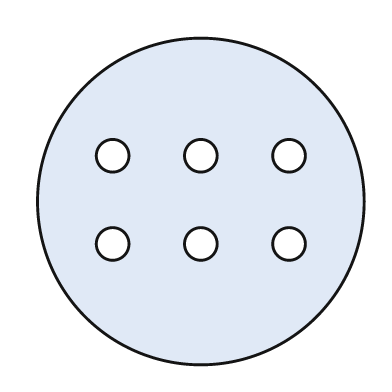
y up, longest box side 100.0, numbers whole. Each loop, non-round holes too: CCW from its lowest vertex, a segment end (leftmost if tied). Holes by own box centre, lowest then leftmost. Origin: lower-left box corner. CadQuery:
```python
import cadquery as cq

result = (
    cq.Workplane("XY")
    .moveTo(50.0, 50.0)
    .circle(50.0)
    .moveTo(23.0, 37.0)
    .circle(5.0)
    .moveTo(50.0, 37.0)
    .circle(5.0)
    .moveTo(77.0, 37.0)
    .circle(5.0)
    .moveTo(23.0, 64.0)
    .circle(5.0)
    .moveTo(50.0, 64.0)
    .circle(5.0)
    .moveTo(77.0, 64.0)
    .circle(5.0)
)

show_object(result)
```